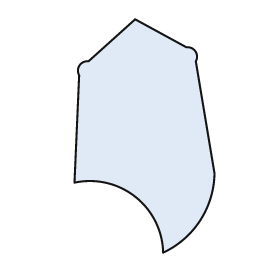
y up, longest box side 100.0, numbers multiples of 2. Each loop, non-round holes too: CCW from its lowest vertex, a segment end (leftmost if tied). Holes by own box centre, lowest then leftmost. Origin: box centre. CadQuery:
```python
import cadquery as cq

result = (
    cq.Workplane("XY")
    .moveTo(8.0, -50.0)
    .threePointArc((24.0, -36.0), (30.0, -16.0))
    .lineTo(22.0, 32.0)
    .threePointArc((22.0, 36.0), (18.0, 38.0))
    .lineTo(-4.0, 50.0)
    .lineTo(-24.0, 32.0)
    .threePointArc((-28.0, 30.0), (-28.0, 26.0))
    .lineTo(-30.0, -20.0)
    .threePointArc((-4.0, -26.0), (8.0, -50.0))
    .close()
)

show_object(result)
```